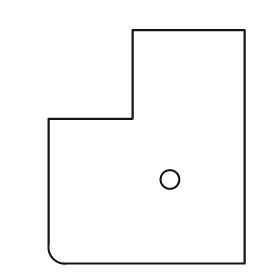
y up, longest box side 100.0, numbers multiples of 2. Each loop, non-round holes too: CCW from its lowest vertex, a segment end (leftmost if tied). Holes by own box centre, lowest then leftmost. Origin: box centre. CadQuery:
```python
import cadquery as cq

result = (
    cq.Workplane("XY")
    .moveTo(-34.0, -50.0)
    .lineTo(42.0, -50.0)
    .lineTo(42.0, 50.0)
    .lineTo(-6.0, 50.0)
    .lineTo(-6.0, 12.0)
    .lineTo(-42.0, 12.0)
    .lineTo(-42.0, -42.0)
    .threePointArc((-40.0, -48.0), (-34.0, -50.0))
    .close()
    .moveTo(10.0, -14.0)
    .circle(4.0)
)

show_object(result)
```